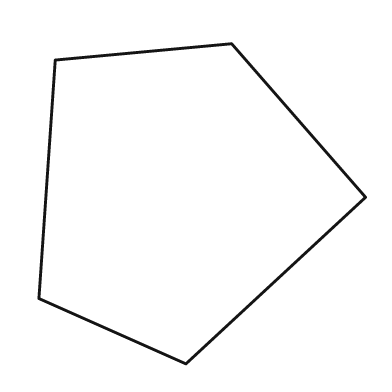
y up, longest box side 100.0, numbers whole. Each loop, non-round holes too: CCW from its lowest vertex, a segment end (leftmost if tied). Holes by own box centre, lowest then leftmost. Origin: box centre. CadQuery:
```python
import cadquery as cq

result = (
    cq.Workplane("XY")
    .moveTo(-5.0, -49.0)
    .lineTo(50.0, 2.0)
    .lineTo(9.0, 49.0)
    .lineTo(-45.0, 44.0)
    .lineTo(-50.0, -29.0)
    .close()
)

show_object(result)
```